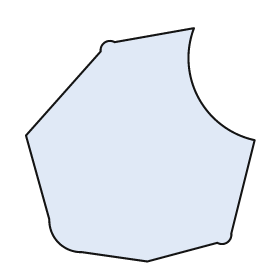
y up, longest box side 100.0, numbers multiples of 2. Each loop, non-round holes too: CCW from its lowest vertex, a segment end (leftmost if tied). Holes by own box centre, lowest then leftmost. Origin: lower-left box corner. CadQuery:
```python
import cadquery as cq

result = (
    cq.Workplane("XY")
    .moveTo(52.0, 0.0)
    .lineTo(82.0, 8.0)
    .threePointArc((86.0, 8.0), (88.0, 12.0))
    .lineTo(98.0, 52.0)
    .threePointArc((74.0, 70.0), (72.0, 100.0))
    .lineTo(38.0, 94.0)
    .threePointArc((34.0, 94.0), (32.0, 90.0))
    .lineTo(0.0, 54.0)
    .lineTo(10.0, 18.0)
    .threePointArc((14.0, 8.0), (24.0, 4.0))
    .close()
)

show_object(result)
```